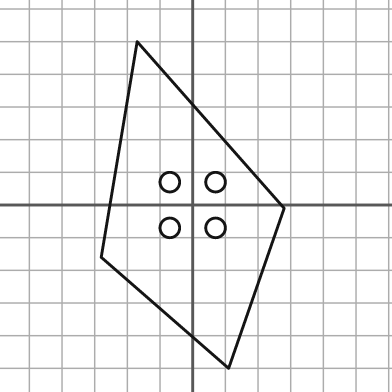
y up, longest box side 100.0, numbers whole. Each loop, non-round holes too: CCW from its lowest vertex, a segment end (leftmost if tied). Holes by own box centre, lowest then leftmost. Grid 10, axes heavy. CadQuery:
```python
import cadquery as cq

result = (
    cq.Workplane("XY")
    .moveTo(11.0, -50.0)
    .lineTo(28.0, -1.0)
    .lineTo(-17.0, 50.0)
    .lineTo(-28.0, -16.0)
    .close()
    .moveTo(-7.0, -7.0)
    .circle(3.0)
    .moveTo(7.0, -7.0)
    .circle(3.0)
    .moveTo(-7.0, 7.0)
    .circle(3.0)
    .moveTo(7.0, 7.0)
    .circle(3.0)
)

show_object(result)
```